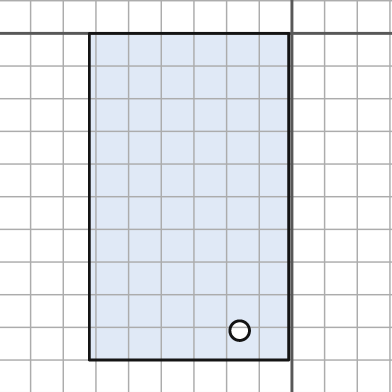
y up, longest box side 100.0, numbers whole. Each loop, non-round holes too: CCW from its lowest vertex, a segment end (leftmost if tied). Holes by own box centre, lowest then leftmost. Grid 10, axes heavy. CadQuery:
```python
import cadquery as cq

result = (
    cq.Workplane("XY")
    .moveTo(-62.0, -100.0)
    .lineTo(-1.0, -100.0)
    .lineTo(-1.0, 0.0)
    .lineTo(-62.0, 0.0)
    .close()
    .moveTo(-16.0, -91.0)
    .circle(3.0)
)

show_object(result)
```